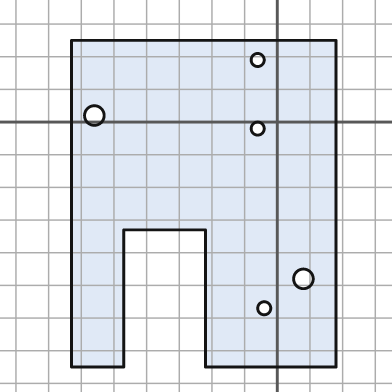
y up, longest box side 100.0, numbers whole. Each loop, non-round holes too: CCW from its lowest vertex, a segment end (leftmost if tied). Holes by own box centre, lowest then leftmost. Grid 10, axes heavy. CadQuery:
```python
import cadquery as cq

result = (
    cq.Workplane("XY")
    .moveTo(-63.0, -75.0)
    .lineTo(-47.0, -75.0)
    .lineTo(-47.0, -33.0)
    .lineTo(-22.0, -33.0)
    .lineTo(-22.0, -75.0)
    .lineTo(18.0, -75.0)
    .lineTo(18.0, 25.0)
    .lineTo(-63.0, 25.0)
    .close()
    .moveTo(-4.0, -57.0)
    .circle(2.0)
    .moveTo(8.0, -48.0)
    .circle(3.0)
    .moveTo(-6.0, -2.0)
    .circle(2.0)
    .moveTo(-56.0, 2.0)
    .circle(3.0)
    .moveTo(-6.0, 19.0)
    .circle(2.0)
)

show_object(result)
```